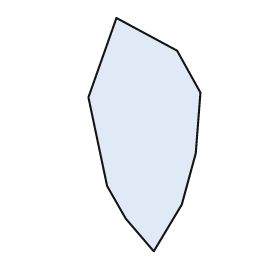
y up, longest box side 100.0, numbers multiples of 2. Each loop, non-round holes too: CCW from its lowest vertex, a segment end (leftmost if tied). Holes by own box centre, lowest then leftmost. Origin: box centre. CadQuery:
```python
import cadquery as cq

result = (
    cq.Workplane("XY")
    .moveTo(4.0, -50.0)
    .lineTo(16.0, -30.0)
    .lineTo(22.0, -8.0)
    .lineTo(24.0, 18.0)
    .lineTo(14.0, 36.0)
    .lineTo(-12.0, 50.0)
    .lineTo(-24.0, 16.0)
    .lineTo(-16.0, -22.0)
    .lineTo(-8.0, -36.0)
    .close()
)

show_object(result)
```